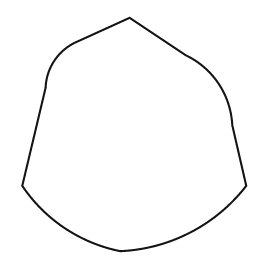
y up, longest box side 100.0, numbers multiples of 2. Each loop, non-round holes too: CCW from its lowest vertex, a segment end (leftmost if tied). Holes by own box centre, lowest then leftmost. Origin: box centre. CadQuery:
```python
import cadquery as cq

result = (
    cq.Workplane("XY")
    .moveTo(-6.0, -50.0)
    .threePointArc((24.0, -42.0), (48.0, -22.0))
    .lineTo(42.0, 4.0)
    .threePointArc((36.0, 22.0), (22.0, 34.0))
    .lineTo(-2.0, 50.0)
    .lineTo(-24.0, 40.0)
    .threePointArc((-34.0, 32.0), (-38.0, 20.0))
    .lineTo(-48.0, -22.0)
    .threePointArc((-30.0, -40.0), (-6.0, -50.0))
    .close()
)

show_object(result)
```